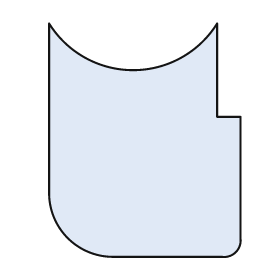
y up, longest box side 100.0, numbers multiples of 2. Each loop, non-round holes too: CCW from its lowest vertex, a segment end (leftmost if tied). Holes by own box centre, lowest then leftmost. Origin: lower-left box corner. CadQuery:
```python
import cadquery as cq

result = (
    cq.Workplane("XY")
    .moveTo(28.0, 0.0)
    .lineTo(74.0, 0.0)
    .threePointArc((80.0, 2.0), (82.0, 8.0))
    .lineTo(82.0, 60.0)
    .lineTo(72.0, 60.0)
    .lineTo(72.0, 100.0)
    .threePointArc((36.0, 80.0), (0.0, 100.0))
    .lineTo(0.0, 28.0)
    .threePointArc((8.0, 8.0), (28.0, 0.0))
    .close()
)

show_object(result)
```